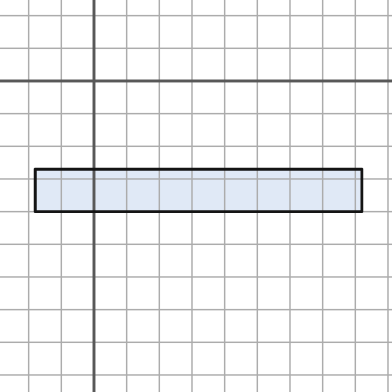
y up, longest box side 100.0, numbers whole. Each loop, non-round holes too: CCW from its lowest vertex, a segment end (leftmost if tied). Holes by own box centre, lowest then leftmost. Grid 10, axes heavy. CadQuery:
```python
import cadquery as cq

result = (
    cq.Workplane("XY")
    .moveTo(-18.0, -40.0)
    .lineTo(82.0, -40.0)
    .lineTo(82.0, -27.0)
    .lineTo(-18.0, -27.0)
    .close()
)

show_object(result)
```